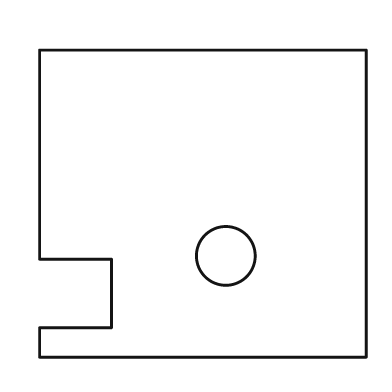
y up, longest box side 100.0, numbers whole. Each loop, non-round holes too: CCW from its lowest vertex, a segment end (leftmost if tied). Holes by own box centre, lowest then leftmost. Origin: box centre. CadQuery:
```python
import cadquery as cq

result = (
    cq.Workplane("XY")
    .moveTo(-50.0, -47.0)
    .lineTo(50.0, -47.0)
    .lineTo(50.0, 47.0)
    .lineTo(-50.0, 47.0)
    .lineTo(-50.0, -17.0)
    .lineTo(-28.0, -17.0)
    .lineTo(-28.0, -38.0)
    .lineTo(-50.0, -38.0)
    .close()
    .moveTo(7.0, -16.0)
    .circle(9.0)
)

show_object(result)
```